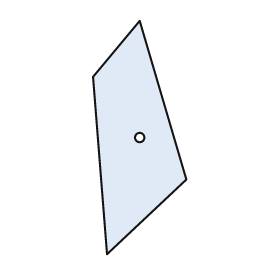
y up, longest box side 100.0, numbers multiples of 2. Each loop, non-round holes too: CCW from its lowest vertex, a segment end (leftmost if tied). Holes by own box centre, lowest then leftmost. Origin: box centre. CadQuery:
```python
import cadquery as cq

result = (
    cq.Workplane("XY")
    .moveTo(-14.0, -50.0)
    .lineTo(20.0, -18.0)
    .lineTo(0.0, 50.0)
    .lineTo(-20.0, 26.0)
    .close()
    .moveTo(0.0, 0.0)
    .circle(2.0)
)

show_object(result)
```